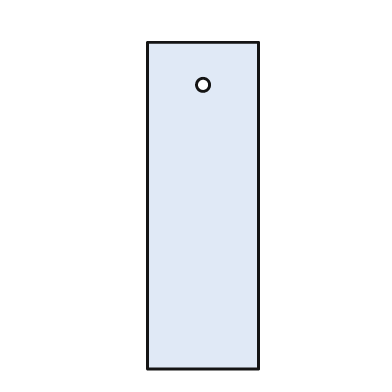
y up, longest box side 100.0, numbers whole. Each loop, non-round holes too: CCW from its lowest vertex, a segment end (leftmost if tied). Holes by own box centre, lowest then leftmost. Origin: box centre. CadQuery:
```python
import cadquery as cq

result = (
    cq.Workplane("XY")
    .moveTo(-17.0, -50.0)
    .lineTo(17.0, -50.0)
    .lineTo(17.0, 50.0)
    .lineTo(-17.0, 50.0)
    .close()
    .moveTo(0.0, 37.0)
    .circle(2.0)
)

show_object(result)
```